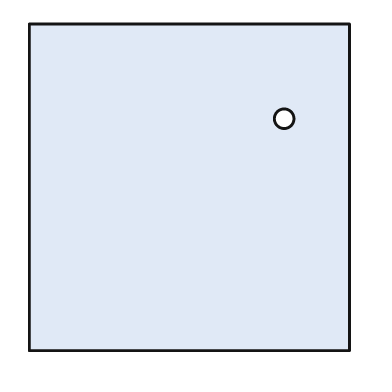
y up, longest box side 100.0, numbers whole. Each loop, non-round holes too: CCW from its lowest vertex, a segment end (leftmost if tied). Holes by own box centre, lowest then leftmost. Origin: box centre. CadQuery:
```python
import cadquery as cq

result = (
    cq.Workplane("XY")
    .moveTo(-49.0, -50.0)
    .lineTo(49.0, -50.0)
    .lineTo(49.0, 50.0)
    .lineTo(-49.0, 50.0)
    .close()
    .moveTo(29.0, 21.0)
    .circle(3.0)
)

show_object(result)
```